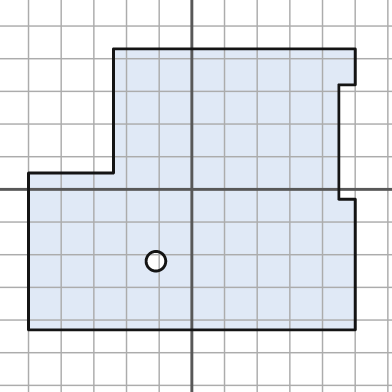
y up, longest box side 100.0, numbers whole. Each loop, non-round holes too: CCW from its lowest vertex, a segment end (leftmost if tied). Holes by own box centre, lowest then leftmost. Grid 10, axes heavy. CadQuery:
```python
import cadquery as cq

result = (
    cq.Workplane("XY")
    .moveTo(-50.0, -43.0)
    .lineTo(50.0, -43.0)
    .lineTo(50.0, -3.0)
    .lineTo(45.0, -3.0)
    .lineTo(45.0, 32.0)
    .lineTo(50.0, 32.0)
    .lineTo(50.0, 43.0)
    .lineTo(-24.0, 43.0)
    .lineTo(-24.0, 5.0)
    .lineTo(-50.0, 5.0)
    .close()
    .moveTo(-11.0, -22.0)
    .circle(3.0)
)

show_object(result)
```